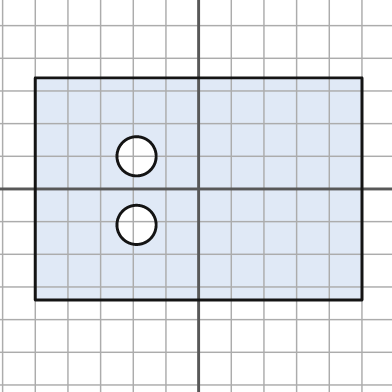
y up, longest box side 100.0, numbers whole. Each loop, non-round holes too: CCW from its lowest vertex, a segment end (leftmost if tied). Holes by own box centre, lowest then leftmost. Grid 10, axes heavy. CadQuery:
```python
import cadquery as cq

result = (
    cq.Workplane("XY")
    .moveTo(-50.0, -34.0)
    .lineTo(50.0, -34.0)
    .lineTo(50.0, 34.0)
    .lineTo(-50.0, 34.0)
    .close()
    .moveTo(-19.0, -11.0)
    .circle(6.0)
    .moveTo(-19.0, 10.0)
    .circle(6.0)
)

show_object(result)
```